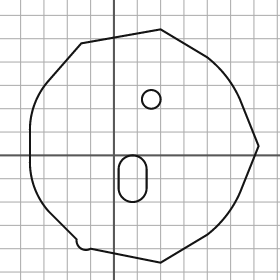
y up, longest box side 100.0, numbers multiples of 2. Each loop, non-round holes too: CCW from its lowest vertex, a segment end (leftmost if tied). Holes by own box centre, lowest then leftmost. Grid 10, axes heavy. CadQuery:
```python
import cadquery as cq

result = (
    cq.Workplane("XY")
    .moveTo(20.0, -46.0)
    .lineTo(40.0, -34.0)
    .threePointArc((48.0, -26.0), (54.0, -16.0))
    .lineTo(62.0, 4.0)
    .lineTo(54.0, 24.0)
    .threePointArc((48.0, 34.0), (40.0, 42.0))
    .lineTo(20.0, 54.0)
    .lineTo(-14.0, 48.0)
    .lineTo(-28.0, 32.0)
    .threePointArc((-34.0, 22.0), (-36.0, 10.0))
    .lineTo(-36.0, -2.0)
    .threePointArc((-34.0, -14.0), (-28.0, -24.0))
    .lineTo(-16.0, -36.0)
    .threePointArc((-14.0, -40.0), (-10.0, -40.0))
    .close()
    .moveTo(2.0, -14.0)
    .threePointArc((8.0, -20.0), (14.0, -14.0))
    .lineTo(14.0, -6.0)
    .threePointArc((8.0, 0.0), (2.0, -6.0))
    .close()
    .moveTo(16.0, 24.0)
    .circle(4.0)
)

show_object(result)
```